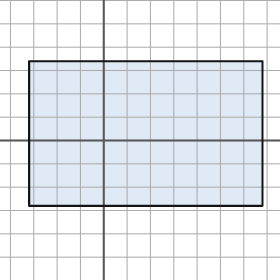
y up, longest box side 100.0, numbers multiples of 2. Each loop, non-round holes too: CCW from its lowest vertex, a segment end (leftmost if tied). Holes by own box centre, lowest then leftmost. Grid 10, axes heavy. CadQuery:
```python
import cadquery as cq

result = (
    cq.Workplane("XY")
    .moveTo(-32.0, -28.0)
    .lineTo(68.0, -28.0)
    .lineTo(68.0, 34.0)
    .lineTo(-32.0, 34.0)
    .close()
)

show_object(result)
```